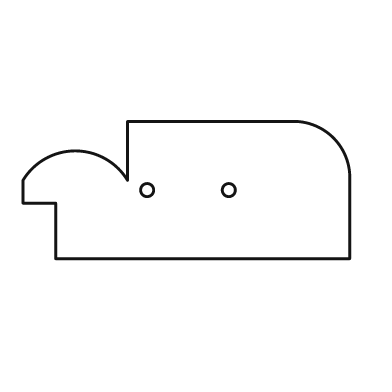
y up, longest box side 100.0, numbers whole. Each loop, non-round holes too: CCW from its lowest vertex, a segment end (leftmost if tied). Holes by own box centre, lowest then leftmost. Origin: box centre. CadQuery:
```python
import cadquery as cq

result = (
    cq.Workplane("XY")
    .moveTo(-40.0, -21.0)
    .lineTo(50.0, -21.0)
    .lineTo(50.0, 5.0)
    .threePointArc((45.0, 16.0), (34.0, 21.0))
    .lineTo(-18.0, 21.0)
    .lineTo(-18.0, 3.0)
    .threePointArc((-34.0, 12.0), (-50.0, 3.0))
    .lineTo(-50.0, -4.0)
    .lineTo(-40.0, -4.0)
    .close()
    .moveTo(-12.0, 0.0)
    .circle(2.0)
    .moveTo(13.0, 0.0)
    .circle(2.0)
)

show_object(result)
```